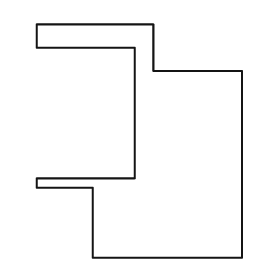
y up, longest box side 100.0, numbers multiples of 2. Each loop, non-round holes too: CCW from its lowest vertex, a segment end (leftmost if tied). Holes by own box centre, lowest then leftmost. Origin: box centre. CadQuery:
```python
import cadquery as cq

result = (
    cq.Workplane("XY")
    .moveTo(-20.0, -50.0)
    .lineTo(44.0, -50.0)
    .lineTo(44.0, 30.0)
    .lineTo(6.0, 30.0)
    .lineTo(6.0, 50.0)
    .lineTo(-44.0, 50.0)
    .lineTo(-44.0, 40.0)
    .lineTo(-2.0, 40.0)
    .lineTo(-2.0, -16.0)
    .lineTo(-44.0, -16.0)
    .lineTo(-44.0, -20.0)
    .lineTo(-20.0, -20.0)
    .close()
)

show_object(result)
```